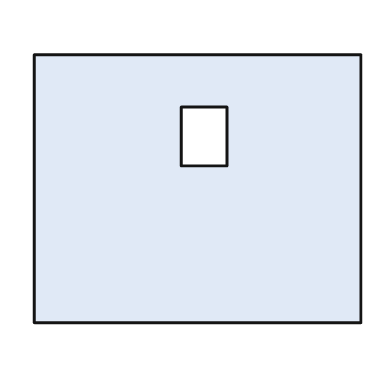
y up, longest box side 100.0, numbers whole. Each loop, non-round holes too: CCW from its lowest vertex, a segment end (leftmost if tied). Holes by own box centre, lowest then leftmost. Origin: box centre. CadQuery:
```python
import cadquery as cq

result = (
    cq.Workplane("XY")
    .moveTo(-50.0, -41.0)
    .lineTo(50.0, -41.0)
    .lineTo(50.0, 41.0)
    .lineTo(-50.0, 41.0)
    .close()
    .moveTo(-5.0, 7.0)
    .lineTo(9.0, 7.0)
    .lineTo(9.0, 25.0)
    .lineTo(-5.0, 25.0)
    .close()
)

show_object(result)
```